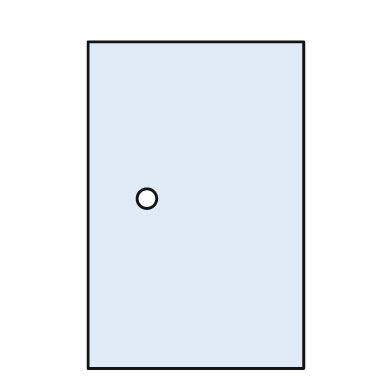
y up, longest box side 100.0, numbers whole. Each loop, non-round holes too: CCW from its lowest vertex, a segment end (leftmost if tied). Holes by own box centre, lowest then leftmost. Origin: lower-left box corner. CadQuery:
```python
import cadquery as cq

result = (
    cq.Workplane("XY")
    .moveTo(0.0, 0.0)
    .lineTo(66.0, 0.0)
    .lineTo(66.0, 100.0)
    .lineTo(0.0, 100.0)
    .close()
    .moveTo(18.0, 52.0)
    .circle(3.0)
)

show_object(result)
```